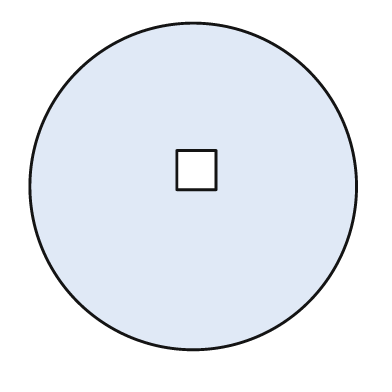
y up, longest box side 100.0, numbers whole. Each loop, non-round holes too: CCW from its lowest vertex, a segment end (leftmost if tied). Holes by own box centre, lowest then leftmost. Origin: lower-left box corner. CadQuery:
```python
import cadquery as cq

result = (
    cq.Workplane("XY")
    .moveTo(50.0, 50.0)
    .circle(50.0)
    .moveTo(45.0, 49.0)
    .lineTo(57.0, 49.0)
    .lineTo(57.0, 61.0)
    .lineTo(45.0, 61.0)
    .close()
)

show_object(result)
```